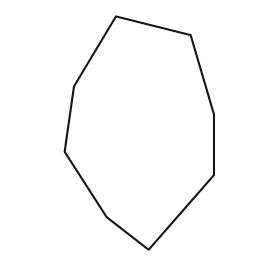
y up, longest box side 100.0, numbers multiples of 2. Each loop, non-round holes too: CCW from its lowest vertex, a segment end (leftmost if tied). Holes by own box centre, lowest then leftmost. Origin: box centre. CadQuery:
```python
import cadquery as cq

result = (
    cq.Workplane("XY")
    .moveTo(4.0, -50.0)
    .lineTo(32.0, -18.0)
    .lineTo(32.0, 8.0)
    .lineTo(22.0, 42.0)
    .lineTo(-10.0, 50.0)
    .lineTo(-28.0, 20.0)
    .lineTo(-32.0, -8.0)
    .lineTo(-14.0, -36.0)
    .close()
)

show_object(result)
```